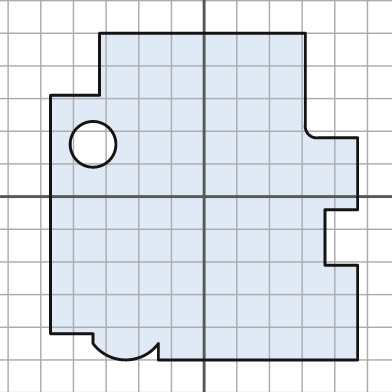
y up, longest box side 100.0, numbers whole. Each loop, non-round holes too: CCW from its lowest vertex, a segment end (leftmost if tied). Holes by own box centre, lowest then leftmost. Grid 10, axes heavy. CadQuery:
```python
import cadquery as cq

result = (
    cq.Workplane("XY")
    .moveTo(-14.0, -50.0)
    .lineTo(47.0, -50.0)
    .lineTo(47.0, -21.0)
    .lineTo(37.0, -21.0)
    .lineTo(37.0, -4.0)
    .lineTo(47.0, -4.0)
    .lineTo(47.0, 18.0)
    .lineTo(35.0, 18.0)
    .threePointArc((32.0, 19.0), (31.0, 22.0))
    .lineTo(31.0, 50.0)
    .lineTo(-32.0, 50.0)
    .lineTo(-32.0, 31.0)
    .lineTo(-47.0, 31.0)
    .lineTo(-47.0, -42.0)
    .lineTo(-34.0, -42.0)
    .lineTo(-34.0, -45.0)
    .threePointArc((-24.0, -50.0), (-14.0, -45.0))
    .close()
    .moveTo(-34.0, 16.0)
    .circle(7.0)
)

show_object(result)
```